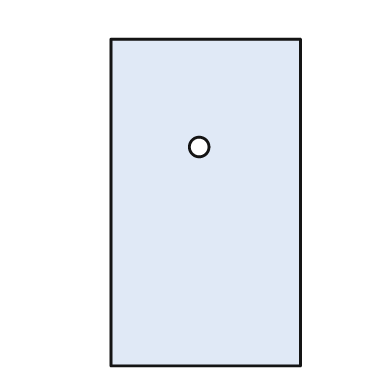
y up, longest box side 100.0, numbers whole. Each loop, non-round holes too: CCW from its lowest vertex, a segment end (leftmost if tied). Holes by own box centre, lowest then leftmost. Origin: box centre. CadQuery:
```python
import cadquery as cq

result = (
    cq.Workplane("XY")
    .moveTo(-29.0, -50.0)
    .lineTo(29.0, -50.0)
    .lineTo(29.0, 50.0)
    .lineTo(-29.0, 50.0)
    .close()
    .moveTo(-2.0, 17.0)
    .circle(3.0)
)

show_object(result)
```